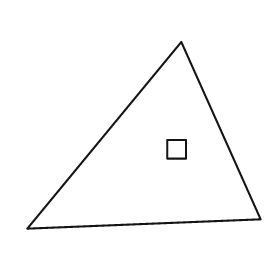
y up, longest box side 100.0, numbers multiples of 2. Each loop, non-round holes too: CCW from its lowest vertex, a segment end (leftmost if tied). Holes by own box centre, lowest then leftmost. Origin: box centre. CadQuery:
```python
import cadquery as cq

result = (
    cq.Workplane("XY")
    .moveTo(-50.0, -40.0)
    .lineTo(50.0, -36.0)
    .lineTo(16.0, 40.0)
    .close()
    .moveTo(10.0, -10.0)
    .lineTo(18.0, -10.0)
    .lineTo(18.0, -2.0)
    .lineTo(10.0, -2.0)
    .close()
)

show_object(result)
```